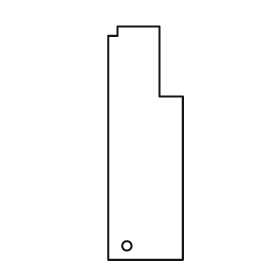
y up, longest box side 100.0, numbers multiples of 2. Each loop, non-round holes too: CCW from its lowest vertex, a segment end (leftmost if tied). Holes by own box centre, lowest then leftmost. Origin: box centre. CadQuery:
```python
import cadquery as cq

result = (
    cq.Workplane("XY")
    .moveTo(-16.0, -50.0)
    .lineTo(16.0, -50.0)
    .lineTo(16.0, 20.0)
    .lineTo(6.0, 20.0)
    .lineTo(6.0, 50.0)
    .lineTo(-12.0, 50.0)
    .lineTo(-12.0, 46.0)
    .lineTo(-16.0, 46.0)
    .close()
    .moveTo(-8.0, -44.0)
    .circle(2.0)
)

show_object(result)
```